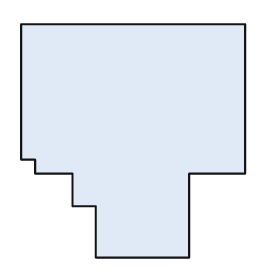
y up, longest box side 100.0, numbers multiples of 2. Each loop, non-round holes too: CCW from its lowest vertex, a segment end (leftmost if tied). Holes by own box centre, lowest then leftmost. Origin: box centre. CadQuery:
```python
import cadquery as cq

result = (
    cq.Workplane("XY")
    .moveTo(-16.0, -50.0)
    .lineTo(24.0, -50.0)
    .lineTo(24.0, -14.0)
    .lineTo(48.0, -14.0)
    .lineTo(48.0, 50.0)
    .lineTo(-48.0, 50.0)
    .lineTo(-48.0, -8.0)
    .lineTo(-42.0, -8.0)
    .lineTo(-42.0, -14.0)
    .lineTo(-26.0, -14.0)
    .lineTo(-26.0, -28.0)
    .lineTo(-16.0, -28.0)
    .close()
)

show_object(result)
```